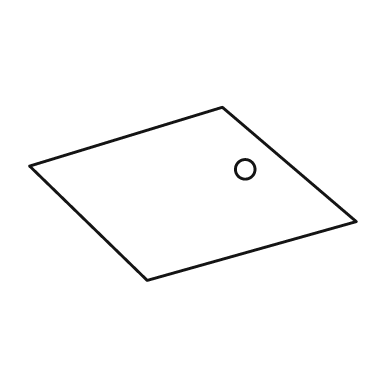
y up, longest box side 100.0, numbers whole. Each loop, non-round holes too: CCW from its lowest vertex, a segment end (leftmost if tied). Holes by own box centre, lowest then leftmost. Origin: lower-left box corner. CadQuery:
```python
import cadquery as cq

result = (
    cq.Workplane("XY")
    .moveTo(36.0, 0.0)
    .lineTo(100.0, 18.0)
    .lineTo(59.0, 53.0)
    .lineTo(0.0, 35.0)
    .close()
    .moveTo(66.0, 34.0)
    .circle(3.0)
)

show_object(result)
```